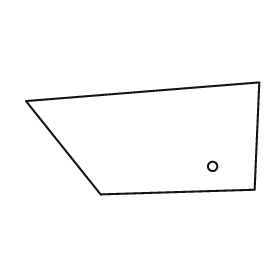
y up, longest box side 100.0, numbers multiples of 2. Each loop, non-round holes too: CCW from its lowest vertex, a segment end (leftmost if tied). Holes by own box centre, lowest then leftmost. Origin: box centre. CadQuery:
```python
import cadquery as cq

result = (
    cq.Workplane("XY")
    .moveTo(-18.0, -24.0)
    .lineTo(48.0, -22.0)
    .lineTo(50.0, 24.0)
    .lineTo(-50.0, 16.0)
    .close()
    .moveTo(30.0, -12.0)
    .circle(2.0)
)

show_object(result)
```